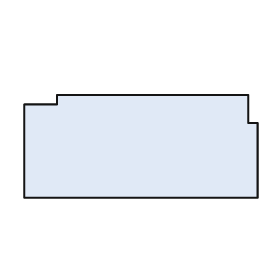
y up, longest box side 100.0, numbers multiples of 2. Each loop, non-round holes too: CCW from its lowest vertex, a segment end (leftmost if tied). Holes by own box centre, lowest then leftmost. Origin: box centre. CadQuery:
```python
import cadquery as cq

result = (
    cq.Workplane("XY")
    .moveTo(-50.0, -22.0)
    .lineTo(50.0, -22.0)
    .lineTo(50.0, 10.0)
    .lineTo(46.0, 10.0)
    .lineTo(46.0, 22.0)
    .lineTo(-36.0, 22.0)
    .lineTo(-36.0, 18.0)
    .lineTo(-50.0, 18.0)
    .close()
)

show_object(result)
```